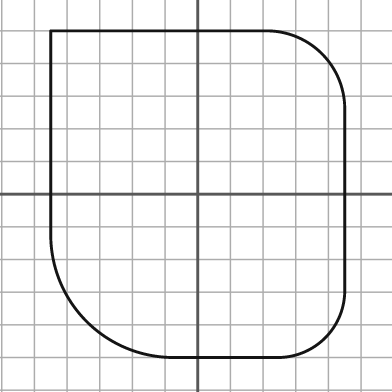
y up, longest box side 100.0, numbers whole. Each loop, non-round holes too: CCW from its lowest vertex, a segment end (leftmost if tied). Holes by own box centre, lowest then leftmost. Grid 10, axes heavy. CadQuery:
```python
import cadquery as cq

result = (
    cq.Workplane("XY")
    .moveTo(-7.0, -50.0)
    .lineTo(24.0, -50.0)
    .threePointArc((39.0, -44.0), (45.0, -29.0))
    .lineTo(45.0, 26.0)
    .threePointArc((38.0, 43.0), (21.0, 50.0))
    .lineTo(-45.0, 50.0)
    .lineTo(-45.0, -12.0)
    .threePointArc((-34.0, -39.0), (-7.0, -50.0))
    .close()
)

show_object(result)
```